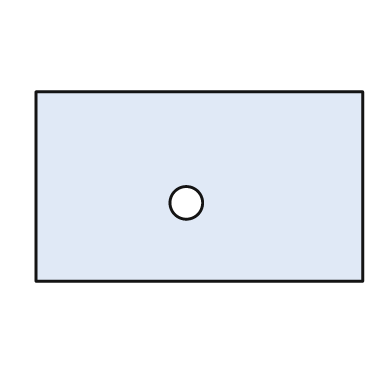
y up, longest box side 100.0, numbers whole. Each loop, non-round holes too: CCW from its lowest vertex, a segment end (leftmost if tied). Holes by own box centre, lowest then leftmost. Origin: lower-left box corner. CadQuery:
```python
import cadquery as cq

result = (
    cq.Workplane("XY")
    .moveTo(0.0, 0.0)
    .lineTo(100.0, 0.0)
    .lineTo(100.0, 58.0)
    .lineTo(0.0, 58.0)
    .close()
    .moveTo(46.0, 24.0)
    .circle(5.0)
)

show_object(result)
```